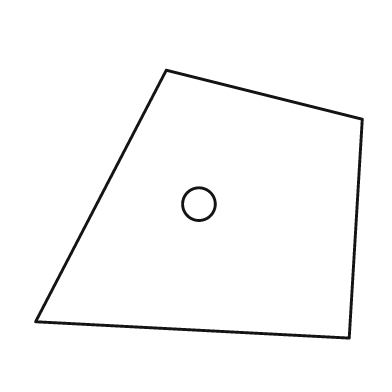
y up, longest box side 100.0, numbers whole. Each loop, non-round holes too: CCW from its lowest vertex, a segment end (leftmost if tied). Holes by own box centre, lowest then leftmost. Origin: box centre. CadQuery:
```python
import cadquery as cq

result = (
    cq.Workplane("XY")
    .moveTo(46.0, -41.0)
    .lineTo(50.0, 26.0)
    .lineTo(-10.0, 41.0)
    .lineTo(-50.0, -36.0)
    .close()
    .moveTo(0.0, 0.0)
    .circle(5.0)
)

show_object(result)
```